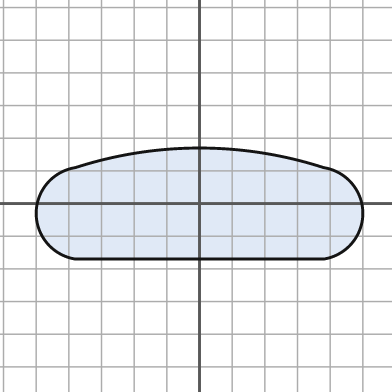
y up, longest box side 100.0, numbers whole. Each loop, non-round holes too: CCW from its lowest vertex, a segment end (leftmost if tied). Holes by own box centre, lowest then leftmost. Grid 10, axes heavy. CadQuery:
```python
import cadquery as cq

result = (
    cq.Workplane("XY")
    .moveTo(-38.0, -17.0)
    .lineTo(38.0, -17.0)
    .threePointArc((50.0, -3.0), (38.0, 11.0))
    .threePointArc((0.0, 17.0), (-38.0, 11.0))
    .threePointArc((-50.0, -3.0), (-38.0, -17.0))
    .close()
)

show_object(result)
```